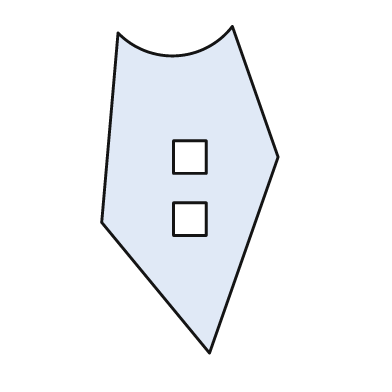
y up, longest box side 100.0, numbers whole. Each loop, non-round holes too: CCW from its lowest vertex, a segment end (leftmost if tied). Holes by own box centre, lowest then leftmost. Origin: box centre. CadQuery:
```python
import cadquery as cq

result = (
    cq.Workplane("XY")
    .moveTo(6.0, -50.0)
    .lineTo(27.0, 10.0)
    .lineTo(13.0, 50.0)
    .threePointArc((-4.0, 41.0), (-22.0, 48.0))
    .lineTo(-27.0, -10.0)
    .close()
    .moveTo(-5.0, -14.0)
    .lineTo(5.0, -14.0)
    .lineTo(5.0, -4.0)
    .lineTo(-5.0, -4.0)
    .close()
    .moveTo(-5.0, 5.0)
    .lineTo(5.0, 5.0)
    .lineTo(5.0, 15.0)
    .lineTo(-5.0, 15.0)
    .close()
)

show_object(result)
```